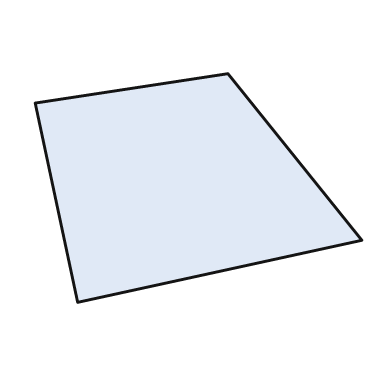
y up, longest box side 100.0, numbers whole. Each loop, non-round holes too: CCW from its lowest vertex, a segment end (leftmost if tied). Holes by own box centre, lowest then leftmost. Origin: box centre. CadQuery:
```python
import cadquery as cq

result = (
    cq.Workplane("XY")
    .moveTo(-37.0, -35.0)
    .lineTo(50.0, -16.0)
    .lineTo(9.0, 35.0)
    .lineTo(-50.0, 26.0)
    .close()
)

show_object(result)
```